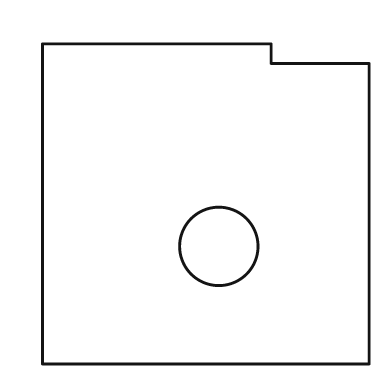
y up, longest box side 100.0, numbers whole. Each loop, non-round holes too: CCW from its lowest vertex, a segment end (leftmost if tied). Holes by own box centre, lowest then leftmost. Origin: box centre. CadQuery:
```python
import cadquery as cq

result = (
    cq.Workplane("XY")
    .moveTo(-50.0, -49.0)
    .lineTo(50.0, -49.0)
    .lineTo(50.0, 43.0)
    .lineTo(20.0, 43.0)
    .lineTo(20.0, 49.0)
    .lineTo(-50.0, 49.0)
    .close()
    .moveTo(4.0, -13.0)
    .circle(12.0)
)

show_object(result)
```